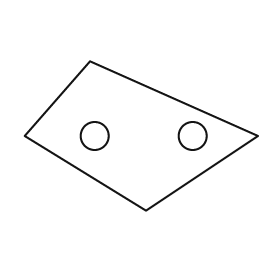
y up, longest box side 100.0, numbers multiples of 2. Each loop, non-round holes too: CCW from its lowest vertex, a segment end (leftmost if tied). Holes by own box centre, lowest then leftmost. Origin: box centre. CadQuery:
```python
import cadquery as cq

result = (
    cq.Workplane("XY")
    .moveTo(2.0, -32.0)
    .lineTo(50.0, 0.0)
    .lineTo(-22.0, 32.0)
    .lineTo(-50.0, 0.0)
    .close()
    .moveTo(-20.0, 0.0)
    .circle(6.0)
    .moveTo(22.0, 0.0)
    .circle(6.0)
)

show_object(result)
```